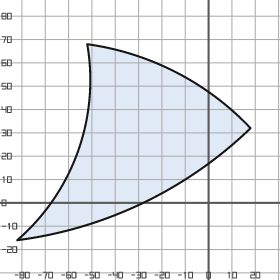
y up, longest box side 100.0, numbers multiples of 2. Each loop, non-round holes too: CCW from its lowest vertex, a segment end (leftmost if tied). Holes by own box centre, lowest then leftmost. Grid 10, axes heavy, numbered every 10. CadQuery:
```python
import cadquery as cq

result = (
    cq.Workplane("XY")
    .moveTo(-82.0, -16.0)
    .threePointArc((-28.0, 0.0), (18.0, 32.0))
    .threePointArc((-14.0, 56.0), (-52.0, 68.0))
    .threePointArc((-56.0, 22.0), (-82.0, -16.0))
    .close()
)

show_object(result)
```